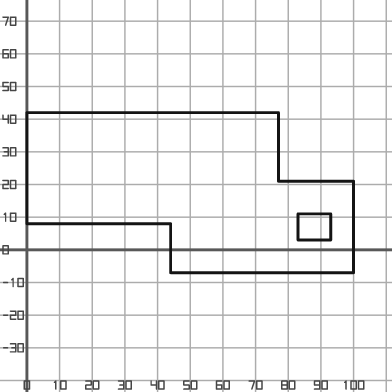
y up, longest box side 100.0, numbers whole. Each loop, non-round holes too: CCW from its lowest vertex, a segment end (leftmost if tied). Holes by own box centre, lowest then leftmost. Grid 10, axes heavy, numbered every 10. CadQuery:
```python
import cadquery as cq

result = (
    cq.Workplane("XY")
    .moveTo(44.0, -7.0)
    .lineTo(100.0, -7.0)
    .lineTo(100.0, 21.0)
    .lineTo(77.0, 21.0)
    .lineTo(77.0, 42.0)
    .lineTo(0.0, 42.0)
    .lineTo(0.0, 8.0)
    .lineTo(44.0, 8.0)
    .close()
    .moveTo(83.0, 3.0)
    .lineTo(93.0, 3.0)
    .lineTo(93.0, 11.0)
    .lineTo(83.0, 11.0)
    .close()
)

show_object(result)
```